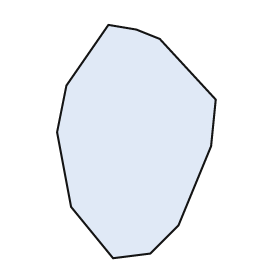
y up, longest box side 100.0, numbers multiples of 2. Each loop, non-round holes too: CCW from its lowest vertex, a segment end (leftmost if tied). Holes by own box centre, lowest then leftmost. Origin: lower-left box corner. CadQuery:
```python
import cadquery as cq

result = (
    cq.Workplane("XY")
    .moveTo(24.0, 0.0)
    .lineTo(40.0, 2.0)
    .lineTo(52.0, 14.0)
    .lineTo(66.0, 48.0)
    .lineTo(68.0, 68.0)
    .lineTo(44.0, 94.0)
    .lineTo(34.0, 98.0)
    .lineTo(22.0, 100.0)
    .lineTo(4.0, 74.0)
    .lineTo(0.0, 54.0)
    .lineTo(6.0, 22.0)
    .close()
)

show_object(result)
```